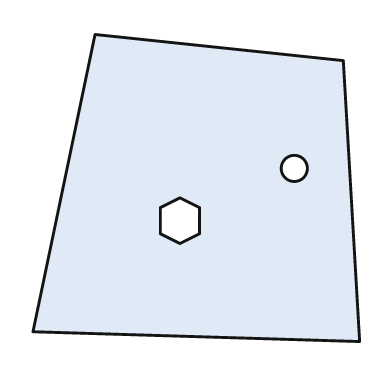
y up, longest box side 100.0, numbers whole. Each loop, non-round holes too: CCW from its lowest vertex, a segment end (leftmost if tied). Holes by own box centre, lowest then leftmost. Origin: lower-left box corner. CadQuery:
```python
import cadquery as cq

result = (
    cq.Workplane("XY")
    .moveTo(100.0, 0.0)
    .lineTo(95.0, 86.0)
    .lineTo(19.0, 94.0)
    .lineTo(0.0, 3.0)
    .close()
    .moveTo(45.0, 30.0)
    .lineTo(51.0, 33.0)
    .lineTo(51.0, 41.0)
    .lineTo(45.0, 44.0)
    .lineTo(39.0, 41.0)
    .lineTo(39.0, 33.0)
    .close()
    .moveTo(80.0, 53.0)
    .circle(4.0)
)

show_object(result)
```